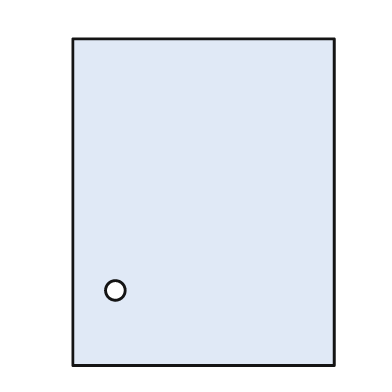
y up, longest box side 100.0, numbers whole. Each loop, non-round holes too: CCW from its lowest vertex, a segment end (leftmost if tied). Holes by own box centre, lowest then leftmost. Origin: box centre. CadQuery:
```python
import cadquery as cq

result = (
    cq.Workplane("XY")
    .moveTo(-40.0, -50.0)
    .lineTo(40.0, -50.0)
    .lineTo(40.0, 50.0)
    .lineTo(-40.0, 50.0)
    .close()
    .moveTo(-27.0, -27.0)
    .circle(3.0)
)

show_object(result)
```